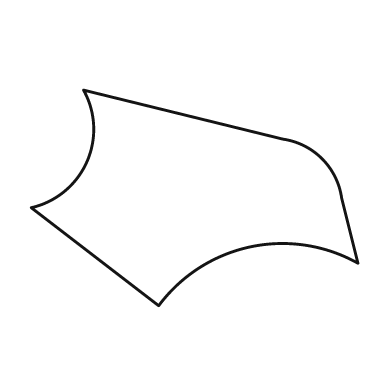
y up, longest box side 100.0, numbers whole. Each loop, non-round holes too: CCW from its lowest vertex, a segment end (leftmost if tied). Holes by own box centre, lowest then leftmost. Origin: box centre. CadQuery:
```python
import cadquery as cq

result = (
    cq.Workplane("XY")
    .moveTo(-11.0, -33.0)
    .threePointArc((17.0, -15.0), (50.0, -20.0))
    .lineTo(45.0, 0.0)
    .threePointArc((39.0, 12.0), (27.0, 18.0))
    .lineTo(-34.0, 33.0)
    .threePointArc((-33.0, 11.0), (-50.0, -3.0))
    .close()
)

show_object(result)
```